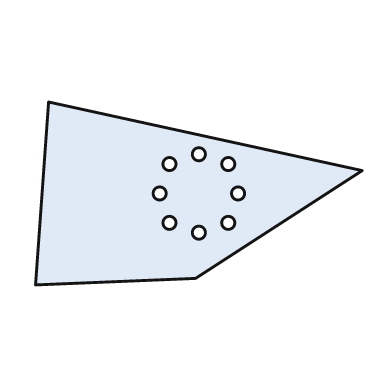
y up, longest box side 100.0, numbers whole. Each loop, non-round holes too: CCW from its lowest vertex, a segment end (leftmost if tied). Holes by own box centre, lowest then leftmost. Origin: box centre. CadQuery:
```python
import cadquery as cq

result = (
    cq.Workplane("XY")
    .moveTo(-50.0, -28.0)
    .lineTo(-1.0, -26.0)
    .lineTo(50.0, 7.0)
    .lineTo(-46.0, 28.0)
    .close()
    .moveTo(0.0, -12.0)
    .circle(2.0)
    .moveTo(-9.0, -9.0)
    .circle(2.0)
    .moveTo(9.0, -9.0)
    .circle(2.0)
    .moveTo(-12.0, 0.0)
    .circle(2.0)
    .moveTo(12.0, 0.0)
    .circle(2.0)
    .moveTo(-9.0, 9.0)
    .circle(2.0)
    .moveTo(9.0, 9.0)
    .circle(2.0)
    .moveTo(0.0, 12.0)
    .circle(2.0)
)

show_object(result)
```